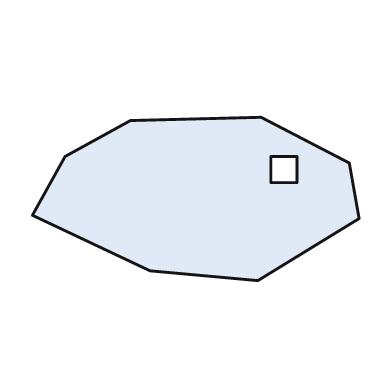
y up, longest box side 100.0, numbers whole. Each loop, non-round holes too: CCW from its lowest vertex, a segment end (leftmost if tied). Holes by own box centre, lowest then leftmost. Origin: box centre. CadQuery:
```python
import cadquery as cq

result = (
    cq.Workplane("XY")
    .moveTo(19.0, -25.0)
    .lineTo(50.0, -6.0)
    .lineTo(47.0, 11.0)
    .lineTo(20.0, 25.0)
    .lineTo(-20.0, 24.0)
    .lineTo(-40.0, 13.0)
    .lineTo(-50.0, -5.0)
    .lineTo(-14.0, -22.0)
    .close()
    .moveTo(23.0, 5.0)
    .lineTo(31.0, 5.0)
    .lineTo(31.0, 13.0)
    .lineTo(23.0, 13.0)
    .close()
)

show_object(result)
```